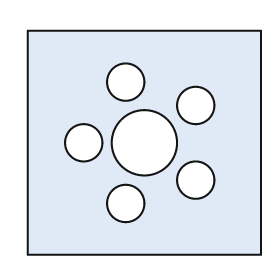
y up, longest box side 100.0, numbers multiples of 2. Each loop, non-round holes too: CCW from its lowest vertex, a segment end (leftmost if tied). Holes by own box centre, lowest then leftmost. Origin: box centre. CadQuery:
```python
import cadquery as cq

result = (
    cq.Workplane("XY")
    .moveTo(-50.0, -48.0)
    .lineTo(50.0, -48.0)
    .lineTo(50.0, 48.0)
    .lineTo(-50.0, 48.0)
    .close()
    .moveTo(-8.0, -26.0)
    .circle(8.0)
    .moveTo(22.0, -16.0)
    .circle(8.0)
    .moveTo(-26.0, 0.0)
    .circle(8.0)
    .moveTo(0.0, 0.0)
    .circle(14.0)
    .moveTo(22.0, 16.0)
    .circle(8.0)
    .moveTo(-8.0, 26.0)
    .circle(8.0)
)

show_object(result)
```